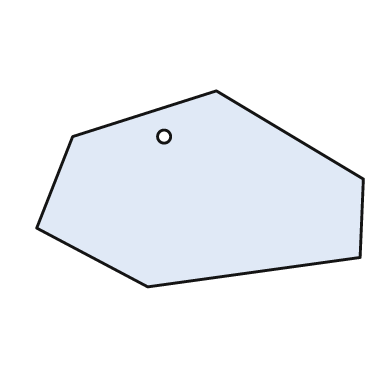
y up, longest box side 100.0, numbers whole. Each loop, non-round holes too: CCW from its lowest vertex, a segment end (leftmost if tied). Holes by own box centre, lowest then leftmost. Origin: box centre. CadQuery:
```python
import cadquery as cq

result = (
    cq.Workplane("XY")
    .moveTo(-16.0, -30.0)
    .lineTo(49.0, -21.0)
    .lineTo(50.0, 3.0)
    .lineTo(5.0, 30.0)
    .lineTo(-39.0, 16.0)
    .lineTo(-50.0, -12.0)
    .close()
    .moveTo(-11.0, 16.0)
    .circle(2.0)
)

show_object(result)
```